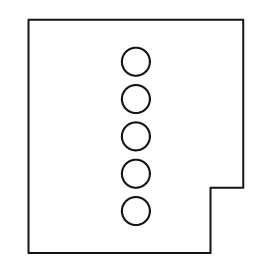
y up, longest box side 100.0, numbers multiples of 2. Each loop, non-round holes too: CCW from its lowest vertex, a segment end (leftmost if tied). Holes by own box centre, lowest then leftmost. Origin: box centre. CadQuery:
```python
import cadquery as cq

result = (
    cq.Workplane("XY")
    .moveTo(-46.0, -50.0)
    .lineTo(32.0, -50.0)
    .lineTo(32.0, -22.0)
    .lineTo(46.0, -22.0)
    .lineTo(46.0, 50.0)
    .lineTo(-46.0, 50.0)
    .close()
    .moveTo(0.0, -32.0)
    .circle(6.0)
    .moveTo(0.0, -16.0)
    .circle(6.0)
    .moveTo(0.0, 0.0)
    .circle(6.0)
    .moveTo(0.0, 16.0)
    .circle(6.0)
    .moveTo(0.0, 32.0)
    .circle(6.0)
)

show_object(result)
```